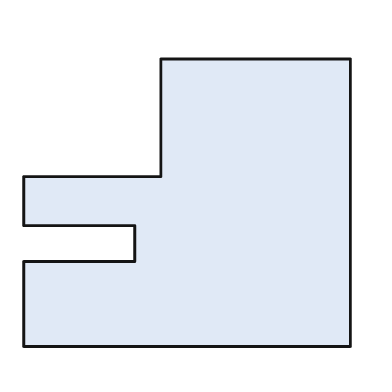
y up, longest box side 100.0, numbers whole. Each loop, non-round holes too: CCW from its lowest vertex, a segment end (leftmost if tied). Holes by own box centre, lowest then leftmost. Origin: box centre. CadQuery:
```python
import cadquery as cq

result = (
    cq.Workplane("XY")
    .moveTo(-50.0, -44.0)
    .lineTo(50.0, -44.0)
    .lineTo(50.0, 44.0)
    .lineTo(-8.0, 44.0)
    .lineTo(-8.0, 8.0)
    .lineTo(-50.0, 8.0)
    .lineTo(-50.0, -7.0)
    .lineTo(-16.0, -7.0)
    .lineTo(-16.0, -18.0)
    .lineTo(-50.0, -18.0)
    .close()
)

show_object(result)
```